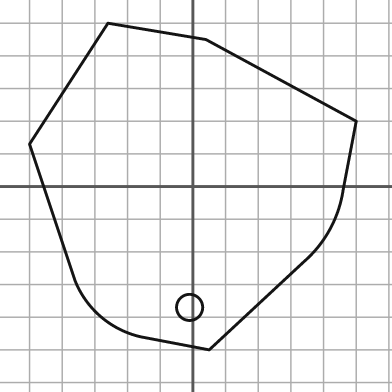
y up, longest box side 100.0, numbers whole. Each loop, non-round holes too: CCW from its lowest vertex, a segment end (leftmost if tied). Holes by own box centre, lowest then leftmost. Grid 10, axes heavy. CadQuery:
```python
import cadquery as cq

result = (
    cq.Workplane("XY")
    .moveTo(5.0, -50.0)
    .lineTo(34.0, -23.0)
    .threePointArc((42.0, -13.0), (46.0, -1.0))
    .lineTo(50.0, 20.0)
    .lineTo(4.0, 45.0)
    .lineTo(-26.0, 50.0)
    .lineTo(-50.0, 13.0)
    .lineTo(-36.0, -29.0)
    .threePointArc((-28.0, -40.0), (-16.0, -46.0))
    .close()
    .moveTo(-1.0, -37.0)
    .circle(4.0)
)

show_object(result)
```